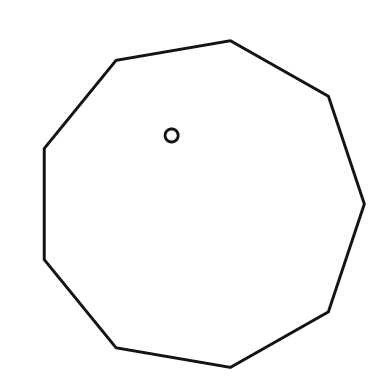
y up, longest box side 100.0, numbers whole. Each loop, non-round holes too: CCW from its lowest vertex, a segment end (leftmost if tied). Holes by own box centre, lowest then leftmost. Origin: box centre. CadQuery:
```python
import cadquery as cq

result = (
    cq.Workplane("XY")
    .moveTo(8.0, -50.0)
    .lineTo(38.0, -33.0)
    .lineTo(49.0, 0.0)
    .lineTo(38.0, 33.0)
    .lineTo(8.0, 50.0)
    .lineTo(-27.0, 44.0)
    .lineTo(-49.0, 17.0)
    .lineTo(-49.0, -17.0)
    .lineTo(-27.0, -44.0)
    .close()
    .moveTo(-10.0, 21.0)
    .circle(2.0)
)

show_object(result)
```